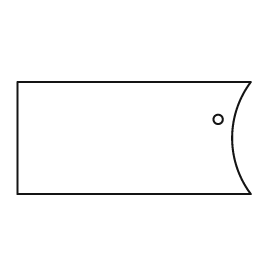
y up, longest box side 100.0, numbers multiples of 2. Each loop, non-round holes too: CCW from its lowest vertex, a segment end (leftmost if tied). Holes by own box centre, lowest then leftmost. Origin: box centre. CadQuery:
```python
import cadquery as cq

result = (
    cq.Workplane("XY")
    .moveTo(-50.0, -24.0)
    .lineTo(50.0, -24.0)
    .threePointArc((42.0, 0.0), (50.0, 24.0))
    .lineTo(-50.0, 24.0)
    .close()
    .moveTo(36.0, 8.0)
    .circle(2.0)
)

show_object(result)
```